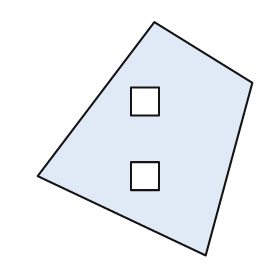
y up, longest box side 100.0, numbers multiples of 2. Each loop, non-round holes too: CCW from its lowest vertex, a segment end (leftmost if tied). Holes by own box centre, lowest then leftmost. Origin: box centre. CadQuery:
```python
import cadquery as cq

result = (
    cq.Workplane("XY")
    .moveTo(26.0, -50.0)
    .lineTo(46.0, 24.0)
    .lineTo(4.0, 50.0)
    .lineTo(-46.0, -16.0)
    .close()
    .moveTo(-6.0, -22.0)
    .lineTo(6.0, -22.0)
    .lineTo(6.0, -10.0)
    .lineTo(-6.0, -10.0)
    .close()
    .moveTo(-6.0, 10.0)
    .lineTo(6.0, 10.0)
    .lineTo(6.0, 22.0)
    .lineTo(-6.0, 22.0)
    .close()
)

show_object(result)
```